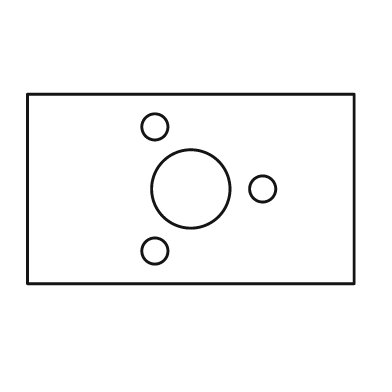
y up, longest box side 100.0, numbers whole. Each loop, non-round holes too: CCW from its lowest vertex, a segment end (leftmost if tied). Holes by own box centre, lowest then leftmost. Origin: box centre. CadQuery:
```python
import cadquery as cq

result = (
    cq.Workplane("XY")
    .moveTo(-50.0, -29.0)
    .lineTo(50.0, -29.0)
    .lineTo(50.0, 29.0)
    .lineTo(-50.0, 29.0)
    .close()
    .moveTo(-11.0, -19.0)
    .circle(4.0)
    .moveTo(0.0, 0.0)
    .circle(12.0)
    .moveTo(22.0, 0.0)
    .circle(4.0)
    .moveTo(-11.0, 19.0)
    .circle(4.0)
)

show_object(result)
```